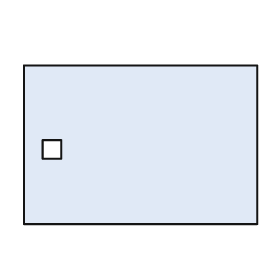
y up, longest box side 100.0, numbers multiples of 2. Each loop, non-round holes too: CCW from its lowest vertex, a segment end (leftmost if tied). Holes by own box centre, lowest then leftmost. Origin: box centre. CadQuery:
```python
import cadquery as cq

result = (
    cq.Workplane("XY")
    .moveTo(-50.0, -34.0)
    .lineTo(50.0, -34.0)
    .lineTo(50.0, 34.0)
    .lineTo(-50.0, 34.0)
    .close()
    .moveTo(-42.0, -6.0)
    .lineTo(-34.0, -6.0)
    .lineTo(-34.0, 2.0)
    .lineTo(-42.0, 2.0)
    .close()
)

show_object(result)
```